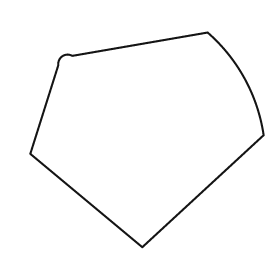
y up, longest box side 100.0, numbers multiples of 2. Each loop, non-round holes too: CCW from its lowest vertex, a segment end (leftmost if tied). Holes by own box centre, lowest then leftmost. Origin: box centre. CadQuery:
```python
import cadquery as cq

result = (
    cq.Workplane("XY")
    .moveTo(-2.0, -46.0)
    .lineTo(50.0, 2.0)
    .threePointArc((42.0, 26.0), (26.0, 46.0))
    .lineTo(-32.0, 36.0)
    .threePointArc((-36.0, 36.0), (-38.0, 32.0))
    .lineTo(-50.0, -6.0)
    .close()
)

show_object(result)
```